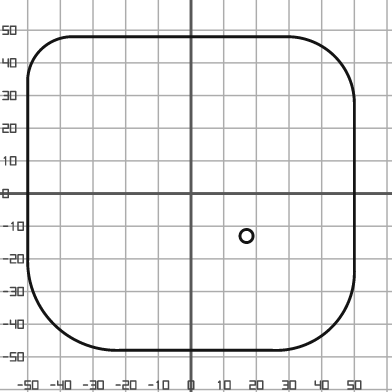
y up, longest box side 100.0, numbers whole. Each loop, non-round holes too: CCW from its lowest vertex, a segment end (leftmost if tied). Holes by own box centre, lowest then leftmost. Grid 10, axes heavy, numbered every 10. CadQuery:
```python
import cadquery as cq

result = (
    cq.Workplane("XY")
    .moveTo(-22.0, -48.0)
    .lineTo(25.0, -48.0)
    .threePointArc((43.0, -41.0), (50.0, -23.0))
    .lineTo(50.0, 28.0)
    .threePointArc((44.0, 42.0), (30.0, 48.0))
    .lineTo(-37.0, 48.0)
    .threePointArc((-46.0, 44.0), (-50.0, 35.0))
    .lineTo(-50.0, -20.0)
    .threePointArc((-42.0, -40.0), (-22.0, -48.0))
    .close()
    .moveTo(17.0, -13.0)
    .circle(2.0)
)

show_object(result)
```